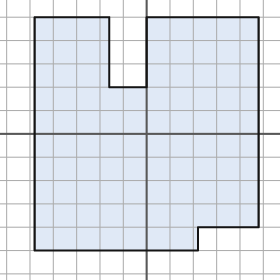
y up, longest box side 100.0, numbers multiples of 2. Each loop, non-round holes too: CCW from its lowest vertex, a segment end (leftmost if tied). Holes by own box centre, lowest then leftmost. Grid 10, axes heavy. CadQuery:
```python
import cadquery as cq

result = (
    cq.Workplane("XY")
    .moveTo(-48.0, -50.0)
    .lineTo(22.0, -50.0)
    .lineTo(22.0, -40.0)
    .lineTo(48.0, -40.0)
    .lineTo(48.0, 50.0)
    .lineTo(0.0, 50.0)
    .lineTo(0.0, 20.0)
    .lineTo(-16.0, 20.0)
    .lineTo(-16.0, 50.0)
    .lineTo(-48.0, 50.0)
    .close()
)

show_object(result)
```